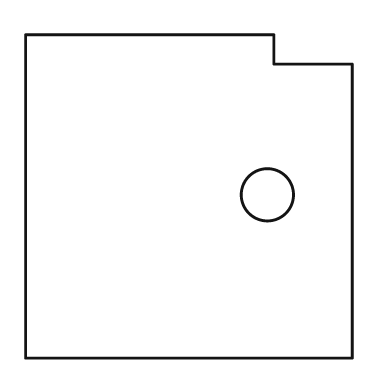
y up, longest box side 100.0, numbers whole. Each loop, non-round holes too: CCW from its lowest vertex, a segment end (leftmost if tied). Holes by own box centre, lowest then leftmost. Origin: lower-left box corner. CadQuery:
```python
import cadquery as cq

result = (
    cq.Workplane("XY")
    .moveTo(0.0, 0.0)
    .lineTo(100.0, 0.0)
    .lineTo(100.0, 90.0)
    .lineTo(76.0, 90.0)
    .lineTo(76.0, 99.0)
    .lineTo(0.0, 99.0)
    .close()
    .moveTo(74.0, 50.0)
    .circle(8.0)
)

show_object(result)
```